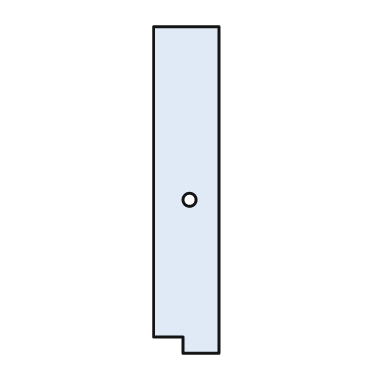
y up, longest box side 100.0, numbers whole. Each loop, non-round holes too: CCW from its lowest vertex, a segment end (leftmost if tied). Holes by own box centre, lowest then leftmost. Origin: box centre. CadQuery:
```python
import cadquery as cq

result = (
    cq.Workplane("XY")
    .moveTo(-1.0, -50.0)
    .lineTo(10.0, -50.0)
    .lineTo(10.0, 50.0)
    .lineTo(-10.0, 50.0)
    .lineTo(-10.0, -45.0)
    .lineTo(-1.0, -45.0)
    .close()
    .moveTo(1.0, -3.0)
    .circle(2.0)
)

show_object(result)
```